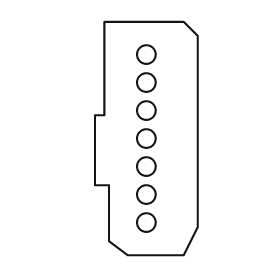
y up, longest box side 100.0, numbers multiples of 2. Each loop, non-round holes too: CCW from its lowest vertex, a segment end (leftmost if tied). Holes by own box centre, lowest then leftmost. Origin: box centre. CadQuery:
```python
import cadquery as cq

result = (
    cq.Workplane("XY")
    .moveTo(-8.0, -50.0)
    .lineTo(16.0, -50.0)
    .lineTo(22.0, -38.0)
    .lineTo(22.0, 44.0)
    .lineTo(16.0, 50.0)
    .lineTo(-18.0, 50.0)
    .lineTo(-18.0, 10.0)
    .lineTo(-22.0, 10.0)
    .lineTo(-22.0, -20.0)
    .lineTo(-16.0, -20.0)
    .lineTo(-16.0, -44.0)
    .close()
    .moveTo(0.0, -36.0)
    .circle(4.0)
    .moveTo(0.0, -24.0)
    .circle(4.0)
    .moveTo(0.0, -12.0)
    .circle(4.0)
    .moveTo(0.0, 0.0)
    .circle(4.0)
    .moveTo(0.0, 12.0)
    .circle(4.0)
    .moveTo(0.0, 24.0)
    .circle(4.0)
    .moveTo(0.0, 36.0)
    .circle(4.0)
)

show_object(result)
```